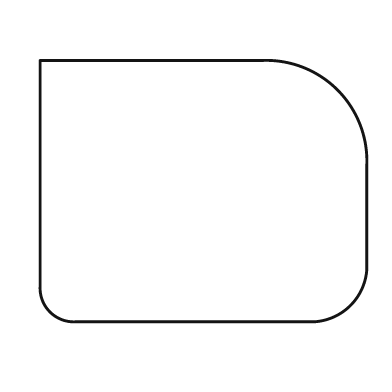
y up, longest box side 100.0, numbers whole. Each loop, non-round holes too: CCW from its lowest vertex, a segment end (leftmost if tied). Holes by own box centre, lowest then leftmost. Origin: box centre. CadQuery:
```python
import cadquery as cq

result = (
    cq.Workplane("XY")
    .moveTo(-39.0, -40.0)
    .lineTo(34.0, -40.0)
    .threePointArc((45.0, -35.0), (50.0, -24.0))
    .lineTo(50.0, 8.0)
    .threePointArc((41.0, 31.0), (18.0, 40.0))
    .lineTo(-50.0, 40.0)
    .lineTo(-50.0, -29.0)
    .threePointArc((-47.0, -37.0), (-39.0, -40.0))
    .close()
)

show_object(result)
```